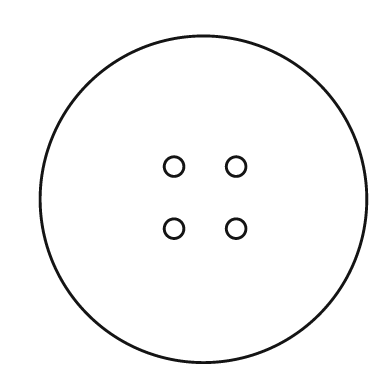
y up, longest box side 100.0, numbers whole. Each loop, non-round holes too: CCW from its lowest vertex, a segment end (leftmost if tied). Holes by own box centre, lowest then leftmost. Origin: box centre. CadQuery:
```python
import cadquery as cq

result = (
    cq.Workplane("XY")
    .moveTo(0.0, 0.0)
    .circle(50.0)
    .moveTo(-9.0, -9.0)
    .circle(3.0)
    .moveTo(10.0, -9.0)
    .circle(3.0)
    .moveTo(-9.0, 10.0)
    .circle(3.0)
    .moveTo(10.0, 10.0)
    .circle(3.0)
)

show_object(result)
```